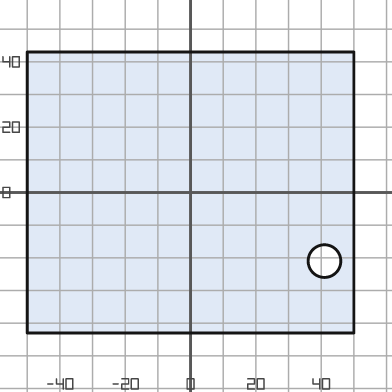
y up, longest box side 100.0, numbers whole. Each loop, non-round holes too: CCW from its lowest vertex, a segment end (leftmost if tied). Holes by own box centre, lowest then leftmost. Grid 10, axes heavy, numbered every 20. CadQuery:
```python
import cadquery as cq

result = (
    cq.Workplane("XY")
    .moveTo(-50.0, -43.0)
    .lineTo(50.0, -43.0)
    .lineTo(50.0, 43.0)
    .lineTo(-50.0, 43.0)
    .close()
    .moveTo(41.0, -21.0)
    .circle(5.0)
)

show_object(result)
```